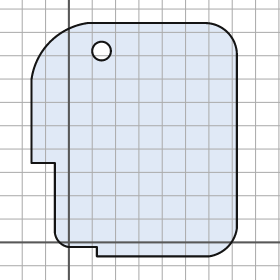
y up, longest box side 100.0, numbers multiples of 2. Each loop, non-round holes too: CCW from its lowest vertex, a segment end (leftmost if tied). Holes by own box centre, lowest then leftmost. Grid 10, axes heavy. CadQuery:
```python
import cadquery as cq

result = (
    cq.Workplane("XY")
    .moveTo(12.0, -6.0)
    .lineTo(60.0, -6.0)
    .threePointArc((68.0, -2.0), (72.0, 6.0))
    .lineTo(72.0, 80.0)
    .threePointArc((68.0, 90.0), (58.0, 94.0))
    .lineTo(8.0, 94.0)
    .threePointArc((-8.0, 86.0), (-16.0, 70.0))
    .lineTo(-16.0, 34.0)
    .lineTo(-6.0, 34.0)
    .lineTo(-6.0, 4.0)
    .threePointArc((-4.0, 0.0), (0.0, -2.0))
    .lineTo(12.0, -2.0)
    .close()
    .moveTo(14.0, 82.0)
    .circle(4.0)
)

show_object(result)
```